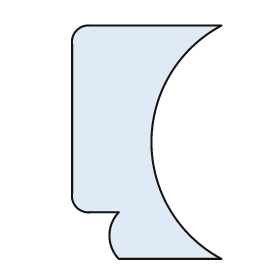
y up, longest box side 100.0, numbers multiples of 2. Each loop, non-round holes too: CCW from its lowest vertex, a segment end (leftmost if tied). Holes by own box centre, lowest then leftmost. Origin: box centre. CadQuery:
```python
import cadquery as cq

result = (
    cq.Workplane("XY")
    .moveTo(-12.0, -50.0)
    .lineTo(32.0, -50.0)
    .threePointArc((2.0, 0.0), (32.0, 50.0))
    .lineTo(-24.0, 50.0)
    .threePointArc((-30.0, 48.0), (-32.0, 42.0))
    .lineTo(-32.0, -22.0)
    .threePointArc((-30.0, -28.0), (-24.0, -30.0))
    .lineTo(-12.0, -30.0)
    .threePointArc((-16.0, -40.0), (-12.0, -50.0))
    .close()
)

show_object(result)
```